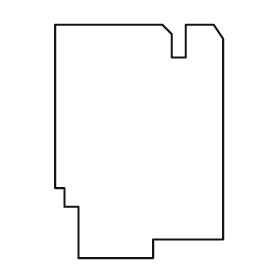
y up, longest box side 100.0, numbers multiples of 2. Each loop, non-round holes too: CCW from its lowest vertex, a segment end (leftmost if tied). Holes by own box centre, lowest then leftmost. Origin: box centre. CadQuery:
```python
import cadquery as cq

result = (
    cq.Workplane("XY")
    .moveTo(-26.0, -50.0)
    .lineTo(6.0, -50.0)
    .lineTo(6.0, -42.0)
    .lineTo(36.0, -42.0)
    .lineTo(36.0, 44.0)
    .lineTo(32.0, 50.0)
    .lineTo(20.0, 50.0)
    .lineTo(20.0, 36.0)
    .lineTo(14.0, 36.0)
    .lineTo(14.0, 46.0)
    .lineTo(10.0, 50.0)
    .lineTo(-36.0, 50.0)
    .lineTo(-36.0, -20.0)
    .lineTo(-32.0, -20.0)
    .lineTo(-32.0, -28.0)
    .lineTo(-26.0, -28.0)
    .close()
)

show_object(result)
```